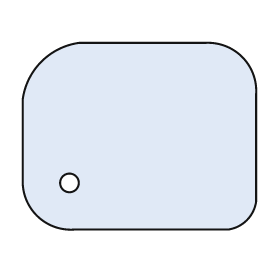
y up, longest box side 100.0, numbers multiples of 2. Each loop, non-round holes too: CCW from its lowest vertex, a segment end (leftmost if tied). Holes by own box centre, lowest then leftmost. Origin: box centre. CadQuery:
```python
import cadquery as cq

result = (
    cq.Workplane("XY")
    .moveTo(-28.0, -40.0)
    .lineTo(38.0, -40.0)
    .threePointArc((46.0, -36.0), (50.0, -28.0))
    .lineTo(50.0, 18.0)
    .threePointArc((44.0, 34.0), (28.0, 40.0))
    .lineTo(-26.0, 40.0)
    .threePointArc((-42.0, 32.0), (-50.0, 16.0))
    .lineTo(-50.0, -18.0)
    .threePointArc((-44.0, -34.0), (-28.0, -40.0))
    .close()
    .moveTo(-30.0, -20.0)
    .circle(4.0)
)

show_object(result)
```